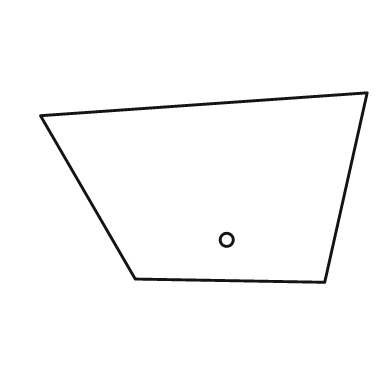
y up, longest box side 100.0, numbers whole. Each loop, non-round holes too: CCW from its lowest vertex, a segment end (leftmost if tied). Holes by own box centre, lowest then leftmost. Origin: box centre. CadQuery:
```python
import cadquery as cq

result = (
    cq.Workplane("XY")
    .moveTo(37.0, -29.0)
    .lineTo(50.0, 29.0)
    .lineTo(-50.0, 22.0)
    .lineTo(-21.0, -28.0)
    .close()
    .moveTo(7.0, -16.0)
    .circle(2.0)
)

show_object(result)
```